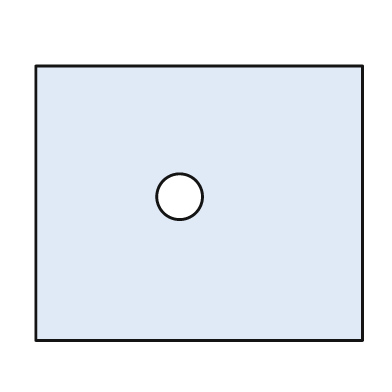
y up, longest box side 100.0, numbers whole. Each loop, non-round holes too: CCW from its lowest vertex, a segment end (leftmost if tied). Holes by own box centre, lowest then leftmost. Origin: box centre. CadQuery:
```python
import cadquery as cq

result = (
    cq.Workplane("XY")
    .moveTo(-50.0, -42.0)
    .lineTo(50.0, -42.0)
    .lineTo(50.0, 42.0)
    .lineTo(-50.0, 42.0)
    .close()
    .moveTo(-6.0, 2.0)
    .circle(7.0)
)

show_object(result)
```